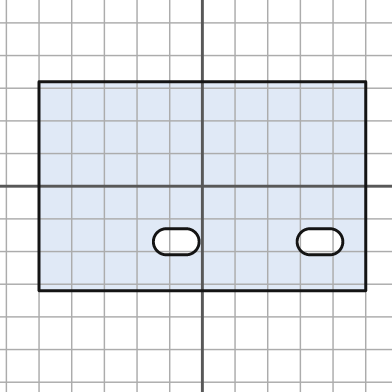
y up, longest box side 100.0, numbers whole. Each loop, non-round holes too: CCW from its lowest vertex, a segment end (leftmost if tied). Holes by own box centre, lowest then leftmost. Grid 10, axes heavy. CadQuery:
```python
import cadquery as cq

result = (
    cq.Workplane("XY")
    .moveTo(-50.0, -32.0)
    .lineTo(50.0, -32.0)
    .lineTo(50.0, 32.0)
    .lineTo(-50.0, 32.0)
    .close()
    .moveTo(-11.0, -21.0)
    .lineTo(-5.0, -21.0)
    .threePointArc((-1.0, -17.0), (-5.0, -13.0))
    .lineTo(-11.0, -13.0)
    .threePointArc((-15.0, -17.0), (-11.0, -21.0))
    .close()
    .moveTo(33.0, -21.0)
    .lineTo(39.0, -21.0)
    .threePointArc((43.0, -17.0), (39.0, -13.0))
    .lineTo(33.0, -13.0)
    .threePointArc((29.0, -17.0), (33.0, -21.0))
    .close()
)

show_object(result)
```